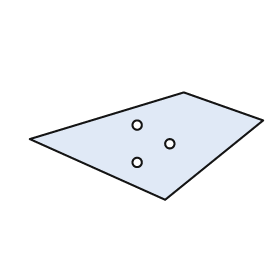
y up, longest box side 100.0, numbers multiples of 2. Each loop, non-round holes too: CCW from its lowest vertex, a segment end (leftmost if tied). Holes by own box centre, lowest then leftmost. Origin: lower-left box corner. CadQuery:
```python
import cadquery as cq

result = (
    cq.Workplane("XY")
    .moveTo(58.0, 0.0)
    .lineTo(100.0, 34.0)
    .lineTo(66.0, 46.0)
    .lineTo(0.0, 26.0)
    .close()
    .moveTo(46.0, 16.0)
    .circle(2.0)
    .moveTo(60.0, 24.0)
    .circle(2.0)
    .moveTo(46.0, 32.0)
    .circle(2.0)
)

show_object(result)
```